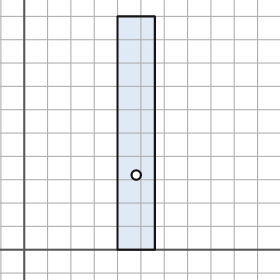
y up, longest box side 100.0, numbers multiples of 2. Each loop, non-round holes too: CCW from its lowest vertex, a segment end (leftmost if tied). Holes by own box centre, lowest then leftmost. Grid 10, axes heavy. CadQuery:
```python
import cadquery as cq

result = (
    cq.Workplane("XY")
    .moveTo(40.0, 0.0)
    .lineTo(56.0, 0.0)
    .lineTo(56.0, 100.0)
    .lineTo(40.0, 100.0)
    .close()
    .moveTo(48.0, 32.0)
    .circle(2.0)
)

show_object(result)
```